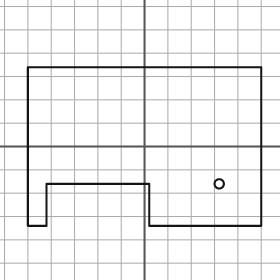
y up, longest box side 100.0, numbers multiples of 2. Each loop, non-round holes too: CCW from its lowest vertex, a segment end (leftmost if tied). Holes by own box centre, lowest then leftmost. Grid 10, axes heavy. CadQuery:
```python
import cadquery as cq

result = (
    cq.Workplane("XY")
    .moveTo(-50.0, -34.0)
    .lineTo(-42.0, -34.0)
    .lineTo(-42.0, -16.0)
    .lineTo(2.0, -16.0)
    .lineTo(2.0, -34.0)
    .lineTo(50.0, -34.0)
    .lineTo(50.0, 34.0)
    .lineTo(-50.0, 34.0)
    .close()
    .moveTo(32.0, -16.0)
    .circle(2.0)
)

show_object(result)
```